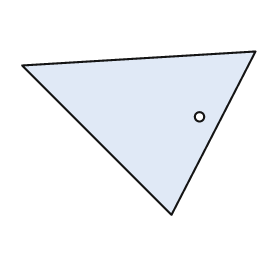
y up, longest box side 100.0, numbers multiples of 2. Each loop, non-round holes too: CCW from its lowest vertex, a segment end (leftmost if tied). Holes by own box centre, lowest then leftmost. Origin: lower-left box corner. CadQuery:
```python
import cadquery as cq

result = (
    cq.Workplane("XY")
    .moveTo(64.0, 0.0)
    .lineTo(100.0, 70.0)
    .lineTo(0.0, 64.0)
    .close()
    .moveTo(76.0, 42.0)
    .circle(2.0)
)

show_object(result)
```